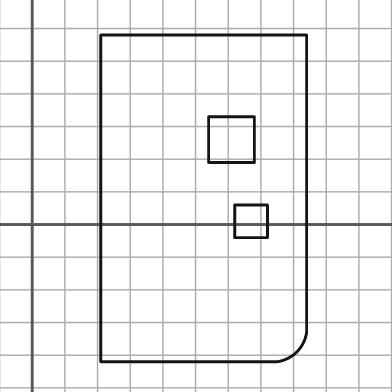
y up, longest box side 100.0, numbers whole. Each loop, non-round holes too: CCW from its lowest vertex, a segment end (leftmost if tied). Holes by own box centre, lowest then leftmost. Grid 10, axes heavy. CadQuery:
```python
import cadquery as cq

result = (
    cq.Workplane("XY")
    .moveTo(21.0, -42.0)
    .lineTo(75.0, -42.0)
    .threePointArc((81.0, -39.0), (84.0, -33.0))
    .lineTo(84.0, 58.0)
    .lineTo(21.0, 58.0)
    .close()
    .moveTo(62.0, -4.0)
    .lineTo(72.0, -4.0)
    .lineTo(72.0, 6.0)
    .lineTo(62.0, 6.0)
    .close()
    .moveTo(54.0, 19.0)
    .lineTo(68.0, 19.0)
    .lineTo(68.0, 33.0)
    .lineTo(54.0, 33.0)
    .close()
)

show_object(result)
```